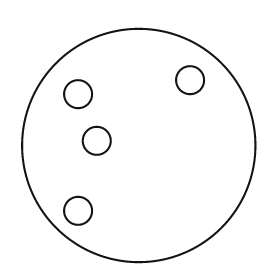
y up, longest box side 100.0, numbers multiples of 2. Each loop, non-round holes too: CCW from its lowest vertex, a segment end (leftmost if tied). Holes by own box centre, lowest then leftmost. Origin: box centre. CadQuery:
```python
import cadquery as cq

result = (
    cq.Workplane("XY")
    .moveTo(0.0, 0.0)
    .circle(50.0)
    .moveTo(-26.0, -28.0)
    .circle(6.0)
    .moveTo(-18.0, 2.0)
    .circle(6.0)
    .moveTo(-26.0, 22.0)
    .circle(6.0)
    .moveTo(22.0, 28.0)
    .circle(6.0)
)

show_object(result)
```